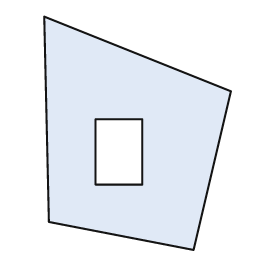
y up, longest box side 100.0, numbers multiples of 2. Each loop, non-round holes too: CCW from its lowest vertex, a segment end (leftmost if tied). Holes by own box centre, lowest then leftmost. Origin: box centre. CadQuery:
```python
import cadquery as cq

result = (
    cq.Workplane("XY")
    .moveTo(24.0, -50.0)
    .lineTo(40.0, 18.0)
    .lineTo(-40.0, 50.0)
    .lineTo(-38.0, -38.0)
    .close()
    .moveTo(-18.0, -22.0)
    .lineTo(2.0, -22.0)
    .lineTo(2.0, 6.0)
    .lineTo(-18.0, 6.0)
    .close()
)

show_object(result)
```